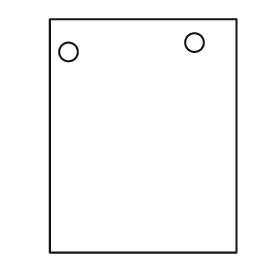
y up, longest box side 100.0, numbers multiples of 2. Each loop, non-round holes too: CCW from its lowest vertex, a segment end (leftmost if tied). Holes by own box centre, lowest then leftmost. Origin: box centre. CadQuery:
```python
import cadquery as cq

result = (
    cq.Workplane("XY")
    .moveTo(-40.0, -50.0)
    .lineTo(40.0, -50.0)
    .lineTo(40.0, 50.0)
    .lineTo(-40.0, 50.0)
    .close()
    .moveTo(-32.0, 36.0)
    .circle(4.0)
    .moveTo(22.0, 40.0)
    .circle(4.0)
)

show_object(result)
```